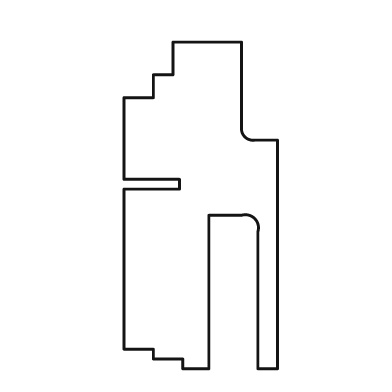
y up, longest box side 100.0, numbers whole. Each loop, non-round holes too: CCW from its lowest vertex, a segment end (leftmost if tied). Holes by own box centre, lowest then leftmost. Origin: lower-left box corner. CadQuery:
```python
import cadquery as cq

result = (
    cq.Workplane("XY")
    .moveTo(18.0, 0.0)
    .lineTo(26.0, 0.0)
    .lineTo(26.0, 47.0)
    .lineTo(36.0, 47.0)
    .threePointArc((40.0, 46.0), (41.0, 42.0))
    .lineTo(41.0, 0.0)
    .lineTo(47.0, 0.0)
    .lineTo(47.0, 70.0)
    .lineTo(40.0, 70.0)
    .threePointArc((37.0, 71.0), (36.0, 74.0))
    .lineTo(36.0, 100.0)
    .lineTo(15.0, 100.0)
    .lineTo(15.0, 90.0)
    .lineTo(9.0, 90.0)
    .lineTo(9.0, 83.0)
    .lineTo(0.0, 83.0)
    .lineTo(0.0, 58.0)
    .lineTo(17.0, 58.0)
    .lineTo(17.0, 55.0)
    .lineTo(0.0, 55.0)
    .lineTo(0.0, 6.0)
    .lineTo(9.0, 6.0)
    .lineTo(9.0, 3.0)
    .lineTo(18.0, 3.0)
    .close()
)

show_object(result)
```